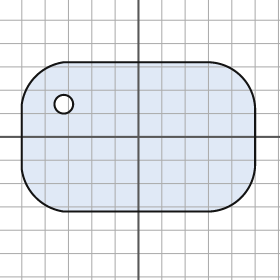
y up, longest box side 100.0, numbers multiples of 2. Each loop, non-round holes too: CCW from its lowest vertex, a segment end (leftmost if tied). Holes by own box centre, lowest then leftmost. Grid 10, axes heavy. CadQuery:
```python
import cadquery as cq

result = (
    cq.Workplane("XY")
    .moveTo(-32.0, -32.0)
    .lineTo(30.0, -32.0)
    .threePointArc((44.0, -26.0), (50.0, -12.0))
    .lineTo(50.0, 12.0)
    .threePointArc((44.0, 26.0), (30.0, 32.0))
    .lineTo(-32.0, 32.0)
    .threePointArc((-44.0, 26.0), (-50.0, 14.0))
    .lineTo(-50.0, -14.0)
    .threePointArc((-44.0, -26.0), (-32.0, -32.0))
    .close()
    .moveTo(-32.0, 14.0)
    .circle(4.0)
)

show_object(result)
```